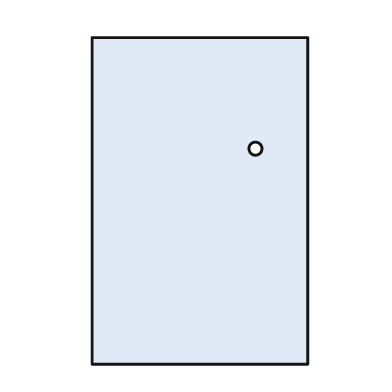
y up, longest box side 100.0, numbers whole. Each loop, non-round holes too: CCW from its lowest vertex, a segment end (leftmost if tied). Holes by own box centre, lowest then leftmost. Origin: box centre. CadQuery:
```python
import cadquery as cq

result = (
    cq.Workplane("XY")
    .moveTo(-33.0, -50.0)
    .lineTo(33.0, -50.0)
    .lineTo(33.0, 50.0)
    .lineTo(-33.0, 50.0)
    .close()
    .moveTo(17.0, 16.0)
    .circle(2.0)
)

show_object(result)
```